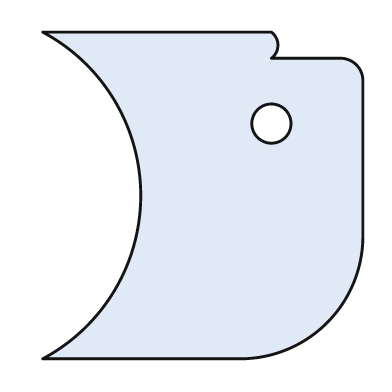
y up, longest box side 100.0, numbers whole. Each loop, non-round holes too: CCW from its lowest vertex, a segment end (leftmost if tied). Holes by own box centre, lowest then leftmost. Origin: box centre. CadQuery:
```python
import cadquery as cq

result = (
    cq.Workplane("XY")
    .moveTo(-49.0, -50.0)
    .lineTo(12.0, -50.0)
    .threePointArc((38.0, -39.0), (49.0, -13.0))
    .lineTo(49.0, 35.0)
    .threePointArc((47.0, 40.0), (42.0, 42.0))
    .lineTo(21.0, 42.0)
    .threePointArc((23.0, 46.0), (21.0, 50.0))
    .lineTo(-49.0, 50.0)
    .threePointArc((-19.0, 0.0), (-49.0, -50.0))
    .close()
    .moveTo(21.0, 22.0)
    .circle(6.0)
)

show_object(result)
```